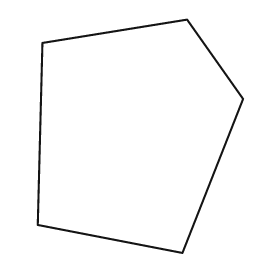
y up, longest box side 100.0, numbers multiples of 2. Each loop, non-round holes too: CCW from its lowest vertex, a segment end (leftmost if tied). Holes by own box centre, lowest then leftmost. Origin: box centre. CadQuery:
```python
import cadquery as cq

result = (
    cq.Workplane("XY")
    .moveTo(18.0, -50.0)
    .lineTo(44.0, 16.0)
    .lineTo(20.0, 50.0)
    .lineTo(-42.0, 40.0)
    .lineTo(-44.0, -38.0)
    .close()
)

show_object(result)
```